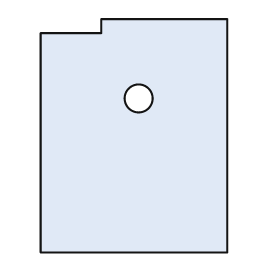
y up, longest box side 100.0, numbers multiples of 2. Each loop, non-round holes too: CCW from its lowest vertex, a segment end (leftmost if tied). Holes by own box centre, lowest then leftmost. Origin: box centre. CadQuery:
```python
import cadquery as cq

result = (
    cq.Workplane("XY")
    .moveTo(-40.0, -50.0)
    .lineTo(40.0, -50.0)
    .lineTo(40.0, 50.0)
    .lineTo(-14.0, 50.0)
    .lineTo(-14.0, 44.0)
    .lineTo(-40.0, 44.0)
    .close()
    .moveTo(2.0, 16.0)
    .circle(6.0)
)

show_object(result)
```